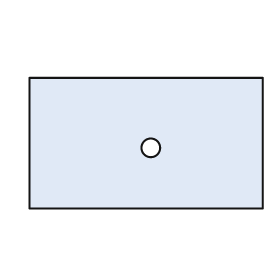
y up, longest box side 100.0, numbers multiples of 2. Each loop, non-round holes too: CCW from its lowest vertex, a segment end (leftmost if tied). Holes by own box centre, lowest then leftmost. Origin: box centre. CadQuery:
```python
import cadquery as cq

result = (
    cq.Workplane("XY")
    .moveTo(-50.0, -28.0)
    .lineTo(50.0, -28.0)
    .lineTo(50.0, 28.0)
    .lineTo(-50.0, 28.0)
    .close()
    .moveTo(2.0, -2.0)
    .circle(4.0)
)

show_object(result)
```